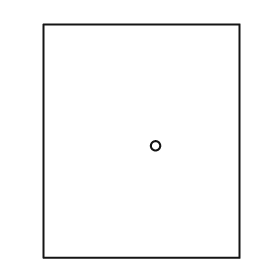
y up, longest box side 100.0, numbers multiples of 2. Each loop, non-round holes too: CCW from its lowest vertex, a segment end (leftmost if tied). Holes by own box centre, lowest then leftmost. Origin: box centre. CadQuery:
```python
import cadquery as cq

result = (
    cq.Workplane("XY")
    .moveTo(-42.0, -50.0)
    .lineTo(42.0, -50.0)
    .lineTo(42.0, 50.0)
    .lineTo(-42.0, 50.0)
    .close()
    .moveTo(6.0, -2.0)
    .circle(2.0)
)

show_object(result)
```